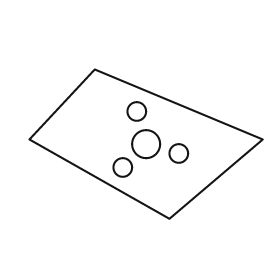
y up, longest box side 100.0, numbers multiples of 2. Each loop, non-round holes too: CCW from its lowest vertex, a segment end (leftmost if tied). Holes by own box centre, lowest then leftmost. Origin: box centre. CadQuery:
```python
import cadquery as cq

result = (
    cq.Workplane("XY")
    .moveTo(10.0, -32.0)
    .lineTo(50.0, 2.0)
    .lineTo(-22.0, 32.0)
    .lineTo(-50.0, 2.0)
    .close()
    .moveTo(-10.0, -10.0)
    .circle(4.0)
    .moveTo(14.0, -4.0)
    .circle(4.0)
    .moveTo(0.0, 0.0)
    .circle(6.0)
    .moveTo(-4.0, 14.0)
    .circle(4.0)
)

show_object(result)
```